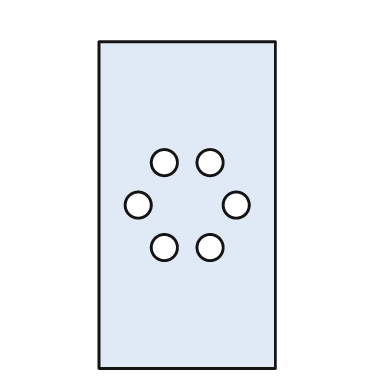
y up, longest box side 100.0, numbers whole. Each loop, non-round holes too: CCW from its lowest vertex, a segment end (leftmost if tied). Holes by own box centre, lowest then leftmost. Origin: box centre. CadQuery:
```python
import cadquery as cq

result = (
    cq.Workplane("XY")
    .moveTo(-27.0, -50.0)
    .lineTo(27.0, -50.0)
    .lineTo(27.0, 50.0)
    .lineTo(-27.0, 50.0)
    .close()
    .moveTo(-7.0, -13.0)
    .circle(4.0)
    .moveTo(7.0, -13.0)
    .circle(4.0)
    .moveTo(-15.0, 0.0)
    .circle(4.0)
    .moveTo(15.0, 0.0)
    .circle(4.0)
    .moveTo(-7.0, 13.0)
    .circle(4.0)
    .moveTo(7.0, 13.0)
    .circle(4.0)
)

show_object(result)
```